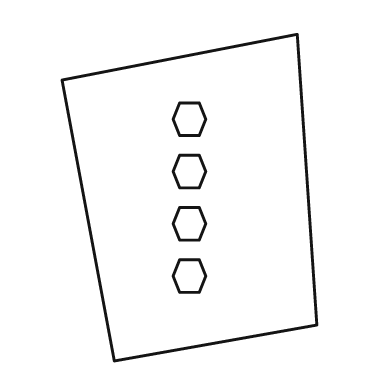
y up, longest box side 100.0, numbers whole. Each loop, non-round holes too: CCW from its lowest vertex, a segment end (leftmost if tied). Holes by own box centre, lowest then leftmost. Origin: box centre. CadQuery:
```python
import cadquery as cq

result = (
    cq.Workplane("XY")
    .moveTo(-23.0, -50.0)
    .lineTo(39.0, -39.0)
    .lineTo(33.0, 50.0)
    .lineTo(-39.0, 36.0)
    .close()
    .moveTo(-3.0, -29.0)
    .lineTo(3.0, -29.0)
    .lineTo(5.0, -24.0)
    .lineTo(3.0, -19.0)
    .lineTo(-3.0, -19.0)
    .lineTo(-5.0, -24.0)
    .close()
    .moveTo(-3.0, -13.0)
    .lineTo(3.0, -13.0)
    .lineTo(5.0, -8.0)
    .lineTo(3.0, -3.0)
    .lineTo(-3.0, -3.0)
    .lineTo(-5.0, -8.0)
    .close()
    .moveTo(-3.0, 3.0)
    .lineTo(3.0, 3.0)
    .lineTo(5.0, 8.0)
    .lineTo(3.0, 13.0)
    .lineTo(-3.0, 13.0)
    .lineTo(-5.0, 8.0)
    .close()
    .moveTo(-3.0, 19.0)
    .lineTo(3.0, 19.0)
    .lineTo(5.0, 24.0)
    .lineTo(3.0, 29.0)
    .lineTo(-3.0, 29.0)
    .lineTo(-5.0, 24.0)
    .close()
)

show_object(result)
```